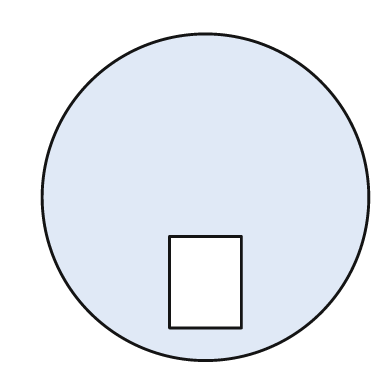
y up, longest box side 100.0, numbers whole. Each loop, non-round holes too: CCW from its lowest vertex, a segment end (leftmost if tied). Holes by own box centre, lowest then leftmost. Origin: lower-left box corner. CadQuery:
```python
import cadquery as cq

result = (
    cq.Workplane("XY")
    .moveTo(50.0, 50.0)
    .circle(50.0)
    .moveTo(39.0, 10.0)
    .lineTo(61.0, 10.0)
    .lineTo(61.0, 38.0)
    .lineTo(39.0, 38.0)
    .close()
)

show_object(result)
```